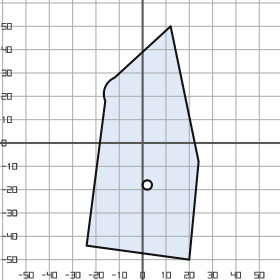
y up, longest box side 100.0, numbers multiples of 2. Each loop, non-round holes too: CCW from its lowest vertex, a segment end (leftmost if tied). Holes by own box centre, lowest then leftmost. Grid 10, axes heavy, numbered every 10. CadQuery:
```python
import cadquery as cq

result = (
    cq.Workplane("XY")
    .moveTo(20.0, -50.0)
    .lineTo(24.0, -8.0)
    .lineTo(12.0, 50.0)
    .lineTo(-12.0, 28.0)
    .threePointArc((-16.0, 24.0), (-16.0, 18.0))
    .lineTo(-24.0, -44.0)
    .close()
    .moveTo(2.0, -18.0)
    .circle(2.0)
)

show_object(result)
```